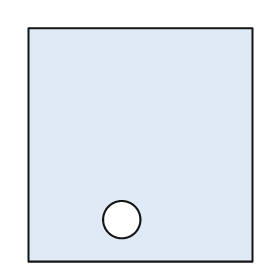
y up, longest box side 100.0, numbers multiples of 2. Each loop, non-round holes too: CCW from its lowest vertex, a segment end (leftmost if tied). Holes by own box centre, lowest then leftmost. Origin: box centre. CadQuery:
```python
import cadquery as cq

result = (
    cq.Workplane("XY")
    .moveTo(-48.0, -50.0)
    .lineTo(48.0, -50.0)
    .lineTo(48.0, 50.0)
    .lineTo(-48.0, 50.0)
    .close()
    .moveTo(-8.0, -32.0)
    .circle(8.0)
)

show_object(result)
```